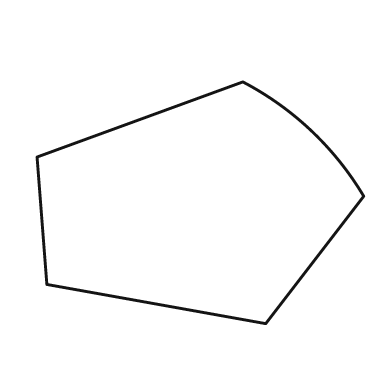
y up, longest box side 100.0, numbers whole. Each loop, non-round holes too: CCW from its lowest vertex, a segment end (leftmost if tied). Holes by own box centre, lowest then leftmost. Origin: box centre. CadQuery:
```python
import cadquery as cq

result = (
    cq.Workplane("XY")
    .moveTo(20.0, -37.0)
    .lineTo(50.0, 2.0)
    .threePointArc((34.0, 22.0), (13.0, 37.0))
    .lineTo(-50.0, 14.0)
    .lineTo(-47.0, -25.0)
    .close()
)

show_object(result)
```